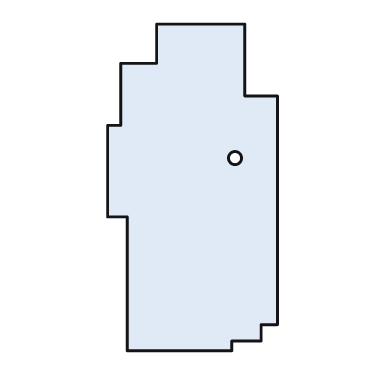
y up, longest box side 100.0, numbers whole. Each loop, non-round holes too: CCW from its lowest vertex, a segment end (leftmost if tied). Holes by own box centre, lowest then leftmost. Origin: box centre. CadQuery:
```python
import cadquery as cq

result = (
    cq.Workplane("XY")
    .moveTo(-20.0, -50.0)
    .lineTo(12.0, -50.0)
    .lineTo(12.0, -47.0)
    .lineTo(21.0, -47.0)
    .lineTo(21.0, -42.0)
    .lineTo(26.0, -42.0)
    .lineTo(26.0, 28.0)
    .lineTo(16.0, 28.0)
    .lineTo(16.0, 50.0)
    .lineTo(-11.0, 50.0)
    .lineTo(-11.0, 38.0)
    .lineTo(-22.0, 38.0)
    .lineTo(-22.0, 19.0)
    .lineTo(-26.0, 19.0)
    .lineTo(-26.0, -9.0)
    .lineTo(-20.0, -9.0)
    .close()
    .moveTo(13.0, 9.0)
    .circle(2.0)
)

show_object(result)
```